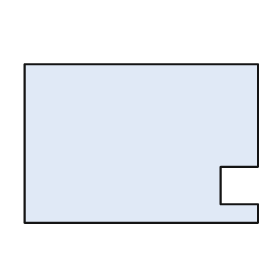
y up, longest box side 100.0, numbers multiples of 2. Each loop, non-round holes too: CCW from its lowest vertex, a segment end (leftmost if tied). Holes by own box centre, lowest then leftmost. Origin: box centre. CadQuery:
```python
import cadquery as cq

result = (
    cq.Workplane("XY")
    .moveTo(-50.0, -34.0)
    .lineTo(50.0, -34.0)
    .lineTo(50.0, -26.0)
    .lineTo(34.0, -26.0)
    .lineTo(34.0, -10.0)
    .lineTo(50.0, -10.0)
    .lineTo(50.0, 34.0)
    .lineTo(-50.0, 34.0)
    .close()
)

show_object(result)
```